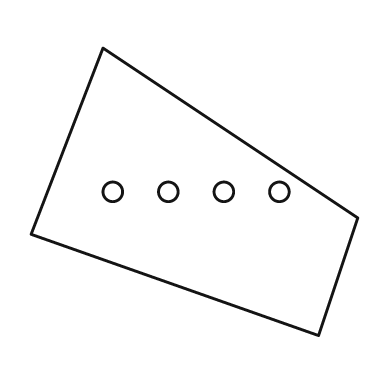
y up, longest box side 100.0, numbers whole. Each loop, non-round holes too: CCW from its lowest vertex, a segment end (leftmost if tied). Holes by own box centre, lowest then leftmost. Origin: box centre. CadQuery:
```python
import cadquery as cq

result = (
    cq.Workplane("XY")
    .moveTo(38.0, -44.0)
    .lineTo(50.0, -8.0)
    .lineTo(-28.0, 44.0)
    .lineTo(-50.0, -13.0)
    .close()
    .moveTo(-25.0, 0.0)
    .circle(3.0)
    .moveTo(-8.0, 0.0)
    .circle(3.0)
    .moveTo(9.0, 0.0)
    .circle(3.0)
    .moveTo(26.0, 0.0)
    .circle(3.0)
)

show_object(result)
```